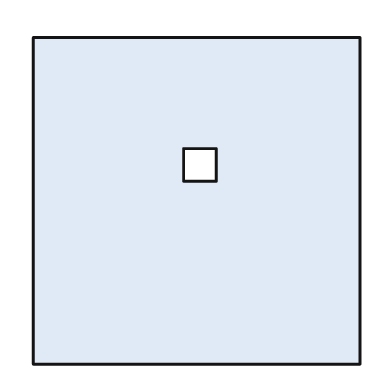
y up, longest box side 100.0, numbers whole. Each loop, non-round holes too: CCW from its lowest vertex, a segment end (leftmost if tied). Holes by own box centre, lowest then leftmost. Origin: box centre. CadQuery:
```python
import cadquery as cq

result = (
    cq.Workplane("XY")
    .moveTo(-50.0, -50.0)
    .lineTo(50.0, -50.0)
    .lineTo(50.0, 50.0)
    .lineTo(-50.0, 50.0)
    .close()
    .moveTo(-4.0, 6.0)
    .lineTo(6.0, 6.0)
    .lineTo(6.0, 16.0)
    .lineTo(-4.0, 16.0)
    .close()
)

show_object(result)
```